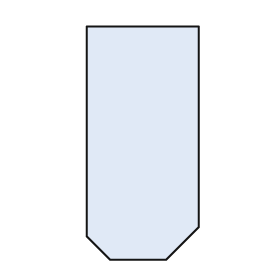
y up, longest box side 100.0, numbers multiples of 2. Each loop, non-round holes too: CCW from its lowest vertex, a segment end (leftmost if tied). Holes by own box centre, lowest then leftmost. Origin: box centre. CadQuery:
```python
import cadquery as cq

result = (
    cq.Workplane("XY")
    .moveTo(-14.0, -50.0)
    .lineTo(10.0, -50.0)
    .lineTo(24.0, -36.0)
    .lineTo(24.0, 50.0)
    .lineTo(-24.0, 50.0)
    .lineTo(-24.0, -40.0)
    .close()
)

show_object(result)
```